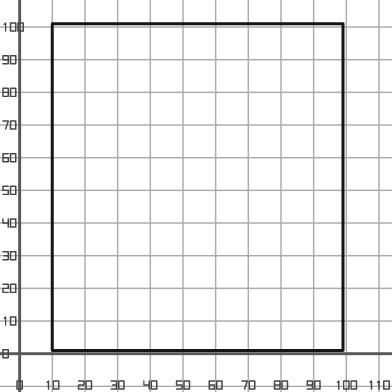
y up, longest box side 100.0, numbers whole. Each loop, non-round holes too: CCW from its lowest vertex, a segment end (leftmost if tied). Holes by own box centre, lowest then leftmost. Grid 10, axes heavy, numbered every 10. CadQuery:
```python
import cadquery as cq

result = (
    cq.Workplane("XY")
    .moveTo(10.0, 1.0)
    .lineTo(99.0, 1.0)
    .lineTo(99.0, 101.0)
    .lineTo(10.0, 101.0)
    .close()
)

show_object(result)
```